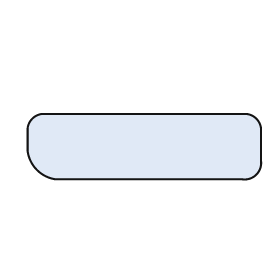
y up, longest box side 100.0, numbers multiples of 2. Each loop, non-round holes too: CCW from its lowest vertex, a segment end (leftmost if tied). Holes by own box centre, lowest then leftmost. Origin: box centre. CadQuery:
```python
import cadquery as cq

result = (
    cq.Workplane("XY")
    .moveTo(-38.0, -14.0)
    .lineTo(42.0, -14.0)
    .threePointArc((48.0, -12.0), (50.0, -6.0))
    .lineTo(50.0, 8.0)
    .threePointArc((48.0, 12.0), (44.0, 14.0))
    .lineTo(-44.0, 14.0)
    .threePointArc((-48.0, 12.0), (-50.0, 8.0))
    .lineTo(-50.0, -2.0)
    .threePointArc((-46.0, -10.0), (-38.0, -14.0))
    .close()
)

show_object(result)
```